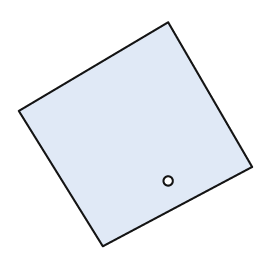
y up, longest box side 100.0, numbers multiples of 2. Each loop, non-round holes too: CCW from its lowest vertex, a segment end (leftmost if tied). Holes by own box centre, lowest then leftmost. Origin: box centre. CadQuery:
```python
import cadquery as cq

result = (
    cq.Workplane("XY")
    .moveTo(-14.0, -48.0)
    .lineTo(50.0, -14.0)
    .lineTo(14.0, 48.0)
    .lineTo(-50.0, 10.0)
    .close()
    .moveTo(14.0, -20.0)
    .circle(2.0)
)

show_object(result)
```